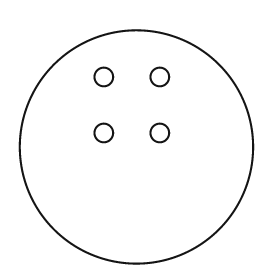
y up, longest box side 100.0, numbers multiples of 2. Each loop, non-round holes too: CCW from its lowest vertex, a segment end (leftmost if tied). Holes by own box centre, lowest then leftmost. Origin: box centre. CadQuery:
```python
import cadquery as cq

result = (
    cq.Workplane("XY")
    .moveTo(0.0, 0.0)
    .circle(50.0)
    .moveTo(-14.0, 6.0)
    .circle(4.0)
    .moveTo(10.0, 6.0)
    .circle(4.0)
    .moveTo(-14.0, 30.0)
    .circle(4.0)
    .moveTo(10.0, 30.0)
    .circle(4.0)
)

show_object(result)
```